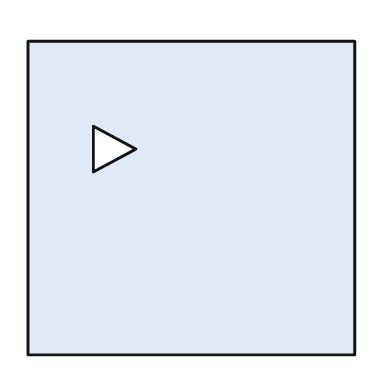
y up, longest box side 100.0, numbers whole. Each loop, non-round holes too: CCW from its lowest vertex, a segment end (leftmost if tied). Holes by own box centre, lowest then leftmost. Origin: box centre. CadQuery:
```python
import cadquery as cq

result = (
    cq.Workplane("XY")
    .moveTo(-50.0, -48.0)
    .lineTo(50.0, -48.0)
    .lineTo(50.0, 48.0)
    .lineTo(-50.0, 48.0)
    .close()
    .moveTo(-30.0, 8.0)
    .lineTo(-17.0, 15.0)
    .lineTo(-30.0, 22.0)
    .close()
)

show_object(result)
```